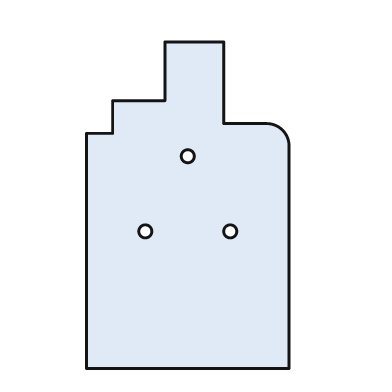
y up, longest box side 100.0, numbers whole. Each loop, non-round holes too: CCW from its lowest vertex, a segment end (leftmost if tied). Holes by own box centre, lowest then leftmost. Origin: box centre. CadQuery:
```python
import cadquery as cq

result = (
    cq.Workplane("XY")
    .moveTo(-31.0, -50.0)
    .lineTo(31.0, -50.0)
    .lineTo(31.0, 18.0)
    .threePointArc((29.0, 23.0), (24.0, 25.0))
    .lineTo(11.0, 25.0)
    .lineTo(11.0, 50.0)
    .lineTo(-7.0, 50.0)
    .lineTo(-7.0, 32.0)
    .lineTo(-23.0, 32.0)
    .lineTo(-23.0, 22.0)
    .lineTo(-31.0, 22.0)
    .close()
    .moveTo(-13.0, -8.0)
    .circle(2.0)
    .moveTo(13.0, -8.0)
    .circle(2.0)
    .moveTo(0.0, 15.0)
    .circle(2.0)
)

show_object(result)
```